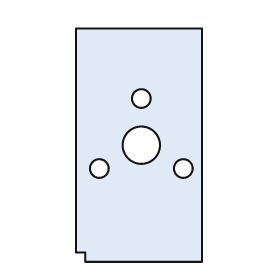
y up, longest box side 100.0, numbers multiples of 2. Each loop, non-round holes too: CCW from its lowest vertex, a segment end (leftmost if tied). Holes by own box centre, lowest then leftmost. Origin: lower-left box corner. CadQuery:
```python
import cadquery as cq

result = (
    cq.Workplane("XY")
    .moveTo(4.0, 0.0)
    .lineTo(54.0, 0.0)
    .lineTo(54.0, 100.0)
    .lineTo(0.0, 100.0)
    .lineTo(0.0, 4.0)
    .lineTo(4.0, 4.0)
    .close()
    .moveTo(10.0, 40.0)
    .circle(4.0)
    .moveTo(46.0, 40.0)
    .circle(4.0)
    .moveTo(28.0, 50.0)
    .circle(8.0)
    .moveTo(28.0, 70.0)
    .circle(4.0)
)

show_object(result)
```